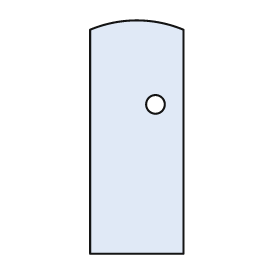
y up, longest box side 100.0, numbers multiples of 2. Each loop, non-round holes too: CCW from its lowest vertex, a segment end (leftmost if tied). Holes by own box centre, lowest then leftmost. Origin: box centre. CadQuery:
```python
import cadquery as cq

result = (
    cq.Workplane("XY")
    .moveTo(-20.0, -50.0)
    .lineTo(20.0, -50.0)
    .lineTo(20.0, 46.0)
    .threePointArc((0.0, 50.0), (-20.0, 46.0))
    .close()
    .moveTo(8.0, 14.0)
    .circle(4.0)
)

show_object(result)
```